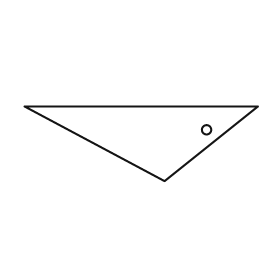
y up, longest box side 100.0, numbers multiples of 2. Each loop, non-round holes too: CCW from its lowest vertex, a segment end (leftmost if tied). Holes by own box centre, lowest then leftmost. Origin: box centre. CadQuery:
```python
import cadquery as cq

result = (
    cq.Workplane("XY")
    .moveTo(10.0, -16.0)
    .lineTo(50.0, 16.0)
    .lineTo(-50.0, 16.0)
    .close()
    .moveTo(28.0, 6.0)
    .circle(2.0)
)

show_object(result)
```